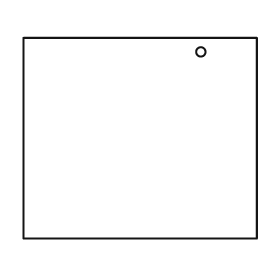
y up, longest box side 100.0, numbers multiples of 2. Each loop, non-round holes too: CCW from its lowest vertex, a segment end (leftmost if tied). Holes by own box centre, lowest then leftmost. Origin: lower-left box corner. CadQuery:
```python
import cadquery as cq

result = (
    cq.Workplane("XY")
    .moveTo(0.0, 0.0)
    .lineTo(100.0, 0.0)
    .lineTo(100.0, 86.0)
    .lineTo(0.0, 86.0)
    .close()
    .moveTo(76.0, 80.0)
    .circle(2.0)
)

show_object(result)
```